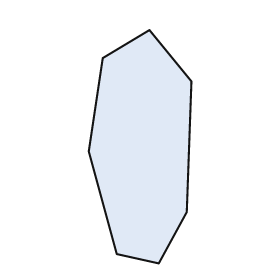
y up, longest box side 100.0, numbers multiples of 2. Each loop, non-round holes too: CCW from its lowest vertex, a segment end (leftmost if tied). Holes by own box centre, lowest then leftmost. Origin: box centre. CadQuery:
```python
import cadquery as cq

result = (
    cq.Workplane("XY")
    .moveTo(8.0, -50.0)
    .lineTo(20.0, -28.0)
    .lineTo(22.0, 28.0)
    .lineTo(4.0, 50.0)
    .lineTo(-16.0, 38.0)
    .lineTo(-22.0, -2.0)
    .lineTo(-10.0, -46.0)
    .close()
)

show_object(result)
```